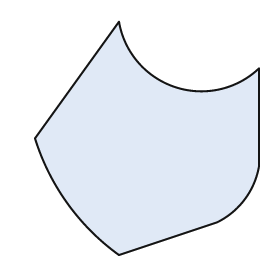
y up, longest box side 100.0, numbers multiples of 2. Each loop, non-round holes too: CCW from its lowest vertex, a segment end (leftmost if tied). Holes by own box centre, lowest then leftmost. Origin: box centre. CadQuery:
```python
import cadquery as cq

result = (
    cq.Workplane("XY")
    .moveTo(-12.0, -50.0)
    .lineTo(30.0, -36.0)
    .threePointArc((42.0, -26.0), (48.0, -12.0))
    .lineTo(48.0, 30.0)
    .threePointArc((12.0, 22.0), (-12.0, 50.0))
    .lineTo(-48.0, 0.0)
    .threePointArc((-34.0, -28.0), (-12.0, -50.0))
    .close()
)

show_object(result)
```